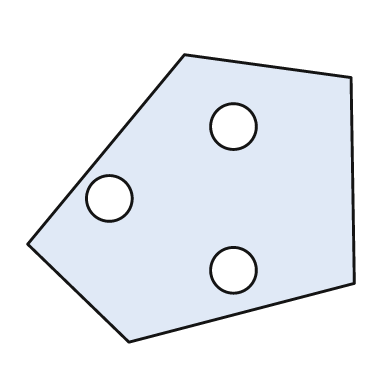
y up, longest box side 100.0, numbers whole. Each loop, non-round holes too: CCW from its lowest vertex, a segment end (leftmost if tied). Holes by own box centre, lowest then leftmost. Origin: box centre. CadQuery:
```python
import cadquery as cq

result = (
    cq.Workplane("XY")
    .moveTo(-19.0, -44.0)
    .lineTo(50.0, -26.0)
    .lineTo(49.0, 37.0)
    .lineTo(-2.0, 44.0)
    .lineTo(-50.0, -14.0)
    .close()
    .moveTo(13.0, -22.0)
    .circle(7.0)
    .moveTo(-25.0, 0.0)
    .circle(7.0)
    .moveTo(13.0, 22.0)
    .circle(7.0)
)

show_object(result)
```